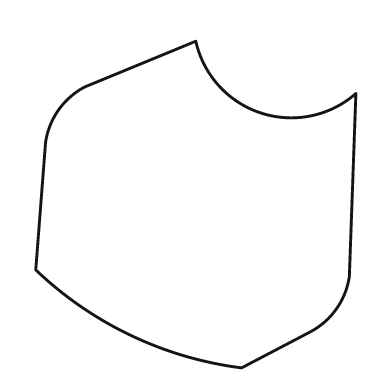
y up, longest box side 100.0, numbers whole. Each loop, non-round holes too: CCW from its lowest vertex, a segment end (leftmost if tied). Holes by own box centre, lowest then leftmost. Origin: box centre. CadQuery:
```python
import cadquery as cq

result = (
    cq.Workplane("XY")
    .moveTo(14.0, -50.0)
    .lineTo(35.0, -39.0)
    .threePointArc((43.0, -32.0), (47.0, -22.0))
    .lineTo(49.0, 34.0)
    .threePointArc((20.0, 28.0), (0.0, 50.0))
    .lineTo(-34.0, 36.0)
    .threePointArc((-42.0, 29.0), (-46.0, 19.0))
    .lineTo(-49.0, -20.0)
    .threePointArc((-20.0, -40.0), (14.0, -50.0))
    .close()
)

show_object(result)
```